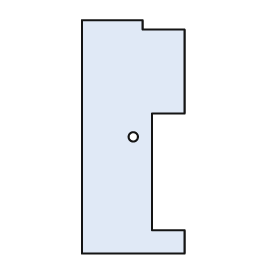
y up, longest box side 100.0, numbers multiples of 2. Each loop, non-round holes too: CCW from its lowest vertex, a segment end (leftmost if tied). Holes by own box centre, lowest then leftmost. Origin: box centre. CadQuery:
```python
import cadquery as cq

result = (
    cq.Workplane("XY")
    .moveTo(-22.0, -50.0)
    .lineTo(22.0, -50.0)
    .lineTo(22.0, -40.0)
    .lineTo(8.0, -40.0)
    .lineTo(8.0, 10.0)
    .lineTo(22.0, 10.0)
    .lineTo(22.0, 46.0)
    .lineTo(4.0, 46.0)
    .lineTo(4.0, 50.0)
    .lineTo(-22.0, 50.0)
    .close()
    .moveTo(0.0, 0.0)
    .circle(2.0)
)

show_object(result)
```